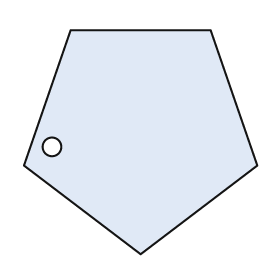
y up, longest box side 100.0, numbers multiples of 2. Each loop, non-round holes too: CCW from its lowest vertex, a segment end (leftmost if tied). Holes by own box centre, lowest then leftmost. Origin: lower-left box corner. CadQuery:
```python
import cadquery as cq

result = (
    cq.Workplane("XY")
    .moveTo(50.0, 0.0)
    .lineTo(100.0, 38.0)
    .lineTo(80.0, 96.0)
    .lineTo(20.0, 96.0)
    .lineTo(0.0, 38.0)
    .close()
    .moveTo(12.0, 46.0)
    .circle(4.0)
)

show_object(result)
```